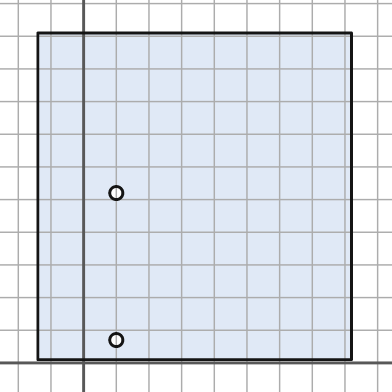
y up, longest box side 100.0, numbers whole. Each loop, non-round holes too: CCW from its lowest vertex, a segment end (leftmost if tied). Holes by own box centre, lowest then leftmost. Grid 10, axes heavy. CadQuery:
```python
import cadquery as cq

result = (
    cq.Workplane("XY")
    .moveTo(-14.0, 1.0)
    .lineTo(82.0, 1.0)
    .lineTo(82.0, 101.0)
    .lineTo(-14.0, 101.0)
    .close()
    .moveTo(10.0, 7.0)
    .circle(2.0)
    .moveTo(10.0, 52.0)
    .circle(2.0)
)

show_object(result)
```